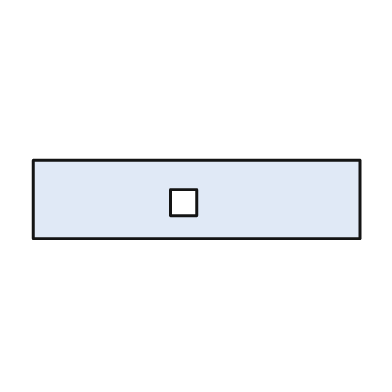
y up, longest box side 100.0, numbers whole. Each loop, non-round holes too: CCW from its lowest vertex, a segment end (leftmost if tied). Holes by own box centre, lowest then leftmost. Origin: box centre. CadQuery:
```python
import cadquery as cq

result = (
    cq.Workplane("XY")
    .moveTo(-50.0, -12.0)
    .lineTo(50.0, -12.0)
    .lineTo(50.0, 12.0)
    .lineTo(-50.0, 12.0)
    .close()
    .moveTo(-8.0, -5.0)
    .lineTo(0.0, -5.0)
    .lineTo(0.0, 3.0)
    .lineTo(-8.0, 3.0)
    .close()
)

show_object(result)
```